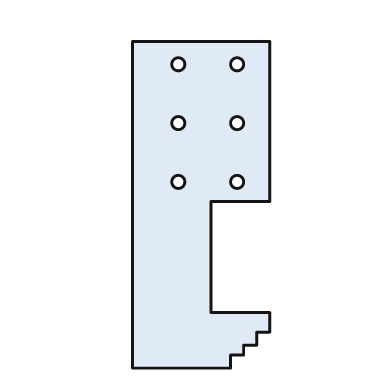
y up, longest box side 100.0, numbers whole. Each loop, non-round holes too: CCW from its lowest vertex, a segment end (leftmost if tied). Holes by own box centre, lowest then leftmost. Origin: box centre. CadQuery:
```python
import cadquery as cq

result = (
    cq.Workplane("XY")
    .moveTo(-21.0, -50.0)
    .lineTo(9.0, -50.0)
    .lineTo(9.0, -46.0)
    .lineTo(13.0, -46.0)
    .lineTo(13.0, -43.0)
    .lineTo(17.0, -43.0)
    .lineTo(17.0, -39.0)
    .lineTo(21.0, -39.0)
    .lineTo(21.0, -33.0)
    .lineTo(3.0, -33.0)
    .lineTo(3.0, 1.0)
    .lineTo(21.0, 1.0)
    .lineTo(21.0, 50.0)
    .lineTo(-21.0, 50.0)
    .close()
    .moveTo(-7.0, 7.0)
    .circle(2.0)
    .moveTo(11.0, 7.0)
    .circle(2.0)
    .moveTo(-7.0, 25.0)
    .circle(2.0)
    .moveTo(11.0, 25.0)
    .circle(2.0)
    .moveTo(-7.0, 43.0)
    .circle(2.0)
    .moveTo(11.0, 43.0)
    .circle(2.0)
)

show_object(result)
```